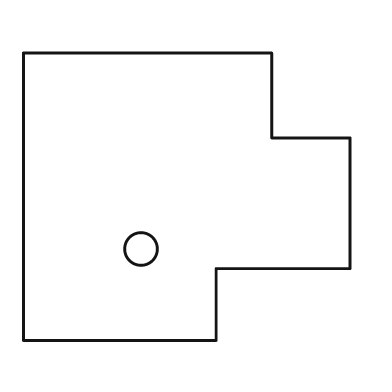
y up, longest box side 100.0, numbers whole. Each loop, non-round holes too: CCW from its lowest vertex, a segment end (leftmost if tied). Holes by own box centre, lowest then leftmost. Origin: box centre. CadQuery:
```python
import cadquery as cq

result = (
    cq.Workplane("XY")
    .moveTo(-50.0, -44.0)
    .lineTo(9.0, -44.0)
    .lineTo(9.0, -22.0)
    .lineTo(50.0, -22.0)
    .lineTo(50.0, 18.0)
    .lineTo(26.0, 18.0)
    .lineTo(26.0, 44.0)
    .lineTo(-50.0, 44.0)
    .close()
    .moveTo(-14.0, -16.0)
    .circle(5.0)
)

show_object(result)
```